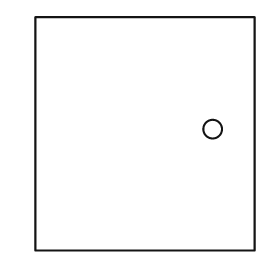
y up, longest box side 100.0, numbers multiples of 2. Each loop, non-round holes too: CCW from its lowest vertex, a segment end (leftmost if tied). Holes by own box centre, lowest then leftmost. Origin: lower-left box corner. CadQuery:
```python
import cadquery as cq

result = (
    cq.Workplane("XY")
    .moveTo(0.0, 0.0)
    .lineTo(94.0, 0.0)
    .lineTo(94.0, 100.0)
    .lineTo(0.0, 100.0)
    .close()
    .moveTo(76.0, 52.0)
    .circle(4.0)
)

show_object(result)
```